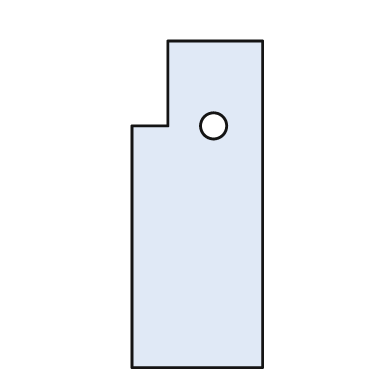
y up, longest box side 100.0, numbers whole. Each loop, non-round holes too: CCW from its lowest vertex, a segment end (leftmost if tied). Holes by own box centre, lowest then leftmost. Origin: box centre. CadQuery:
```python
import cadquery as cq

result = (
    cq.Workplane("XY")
    .moveTo(-20.0, -50.0)
    .lineTo(20.0, -50.0)
    .lineTo(20.0, 50.0)
    .lineTo(-9.0, 50.0)
    .lineTo(-9.0, 24.0)
    .lineTo(-20.0, 24.0)
    .close()
    .moveTo(5.0, 24.0)
    .circle(4.0)
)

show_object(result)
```